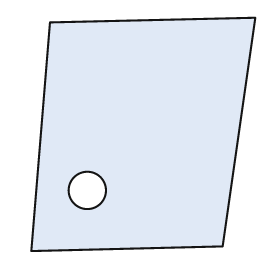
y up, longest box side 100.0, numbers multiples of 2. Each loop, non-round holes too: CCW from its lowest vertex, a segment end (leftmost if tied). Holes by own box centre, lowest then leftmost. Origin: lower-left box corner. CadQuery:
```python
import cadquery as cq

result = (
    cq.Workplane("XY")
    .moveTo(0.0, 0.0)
    .lineTo(82.0, 2.0)
    .lineTo(96.0, 100.0)
    .lineTo(8.0, 98.0)
    .close()
    .moveTo(24.0, 26.0)
    .circle(8.0)
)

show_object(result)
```